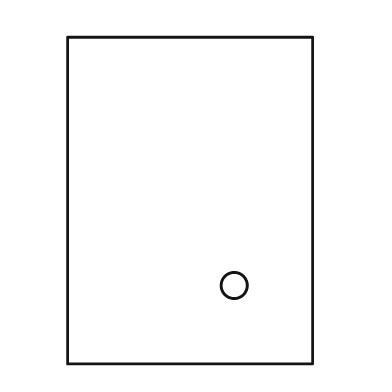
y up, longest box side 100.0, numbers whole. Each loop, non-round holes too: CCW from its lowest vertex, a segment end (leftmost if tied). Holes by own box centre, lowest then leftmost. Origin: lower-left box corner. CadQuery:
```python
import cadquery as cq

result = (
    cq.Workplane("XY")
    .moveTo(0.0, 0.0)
    .lineTo(75.0, 0.0)
    .lineTo(75.0, 100.0)
    .lineTo(0.0, 100.0)
    .close()
    .moveTo(51.0, 24.0)
    .circle(4.0)
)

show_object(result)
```